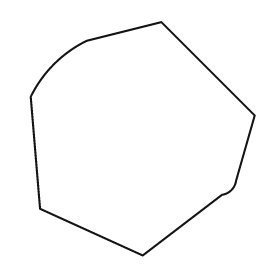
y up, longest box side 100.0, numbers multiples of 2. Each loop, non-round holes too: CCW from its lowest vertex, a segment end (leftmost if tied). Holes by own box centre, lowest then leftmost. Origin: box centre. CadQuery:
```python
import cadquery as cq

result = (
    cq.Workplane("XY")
    .moveTo(0.0, -50.0)
    .lineTo(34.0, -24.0)
    .threePointArc((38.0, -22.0), (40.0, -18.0))
    .lineTo(48.0, 10.0)
    .lineTo(8.0, 50.0)
    .lineTo(-24.0, 42.0)
    .threePointArc((-38.0, 32.0), (-48.0, 18.0))
    .lineTo(-44.0, -30.0)
    .close()
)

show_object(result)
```